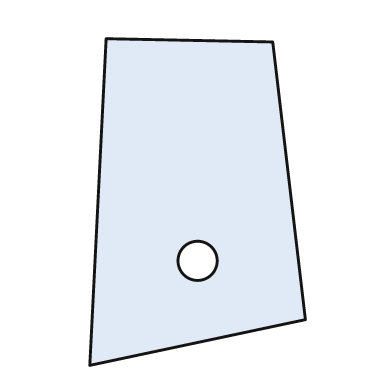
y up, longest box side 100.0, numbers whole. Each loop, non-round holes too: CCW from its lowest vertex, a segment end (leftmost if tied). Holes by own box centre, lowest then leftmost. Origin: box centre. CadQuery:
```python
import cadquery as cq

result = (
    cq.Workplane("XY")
    .moveTo(-33.0, -50.0)
    .lineTo(33.0, -36.0)
    .lineTo(23.0, 49.0)
    .lineTo(-28.0, 50.0)
    .close()
    .moveTo(0.0, -18.0)
    .circle(6.0)
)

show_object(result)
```